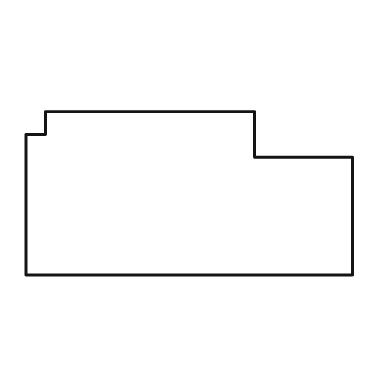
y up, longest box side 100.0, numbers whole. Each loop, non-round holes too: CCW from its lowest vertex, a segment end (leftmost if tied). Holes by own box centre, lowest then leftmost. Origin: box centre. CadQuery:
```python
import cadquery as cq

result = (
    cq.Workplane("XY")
    .moveTo(-50.0, -25.0)
    .lineTo(50.0, -25.0)
    .lineTo(50.0, 11.0)
    .lineTo(20.0, 11.0)
    .lineTo(20.0, 25.0)
    .lineTo(-44.0, 25.0)
    .lineTo(-44.0, 18.0)
    .lineTo(-50.0, 18.0)
    .close()
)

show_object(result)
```